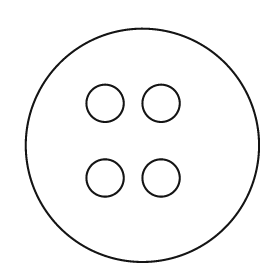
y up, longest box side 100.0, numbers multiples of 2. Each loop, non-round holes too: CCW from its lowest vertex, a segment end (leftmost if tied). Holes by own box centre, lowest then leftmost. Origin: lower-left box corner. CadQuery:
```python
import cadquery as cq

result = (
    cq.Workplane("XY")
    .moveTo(50.0, 50.0)
    .circle(50.0)
    .moveTo(34.0, 36.0)
    .circle(8.0)
    .moveTo(58.0, 36.0)
    .circle(8.0)
    .moveTo(34.0, 68.0)
    .circle(8.0)
    .moveTo(58.0, 68.0)
    .circle(8.0)
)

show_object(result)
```